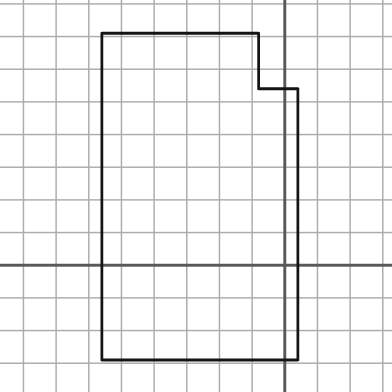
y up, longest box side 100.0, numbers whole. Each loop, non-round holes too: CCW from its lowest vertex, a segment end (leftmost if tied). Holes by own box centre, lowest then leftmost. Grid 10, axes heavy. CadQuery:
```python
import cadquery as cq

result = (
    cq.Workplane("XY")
    .moveTo(-56.0, -29.0)
    .lineTo(4.0, -29.0)
    .lineTo(4.0, 54.0)
    .lineTo(-8.0, 54.0)
    .lineTo(-8.0, 71.0)
    .lineTo(-56.0, 71.0)
    .close()
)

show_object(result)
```